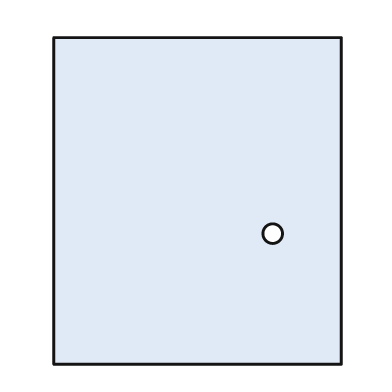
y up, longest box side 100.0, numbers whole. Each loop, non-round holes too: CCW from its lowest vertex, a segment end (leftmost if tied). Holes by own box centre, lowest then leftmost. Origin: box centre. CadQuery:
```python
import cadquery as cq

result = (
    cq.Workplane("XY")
    .moveTo(-44.0, -50.0)
    .lineTo(44.0, -50.0)
    .lineTo(44.0, 50.0)
    .lineTo(-44.0, 50.0)
    .close()
    .moveTo(23.0, -10.0)
    .circle(3.0)
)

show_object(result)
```